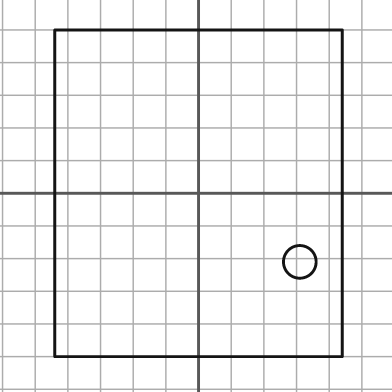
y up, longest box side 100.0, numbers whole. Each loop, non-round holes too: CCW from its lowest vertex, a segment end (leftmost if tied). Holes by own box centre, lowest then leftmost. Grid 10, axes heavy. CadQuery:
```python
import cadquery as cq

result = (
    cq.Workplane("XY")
    .moveTo(-44.0, -50.0)
    .lineTo(44.0, -50.0)
    .lineTo(44.0, 50.0)
    .lineTo(-44.0, 50.0)
    .close()
    .moveTo(31.0, -21.0)
    .circle(5.0)
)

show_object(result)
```